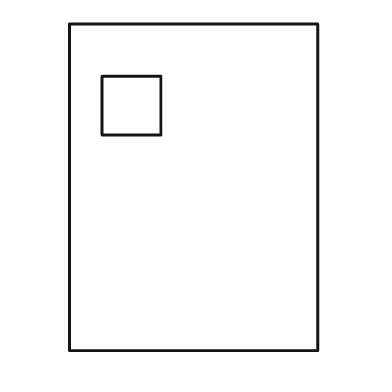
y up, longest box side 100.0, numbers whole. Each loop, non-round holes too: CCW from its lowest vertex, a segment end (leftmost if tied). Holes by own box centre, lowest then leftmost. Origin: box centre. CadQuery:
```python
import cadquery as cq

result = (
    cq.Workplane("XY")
    .moveTo(-38.0, -50.0)
    .lineTo(38.0, -50.0)
    .lineTo(38.0, 50.0)
    .lineTo(-38.0, 50.0)
    .close()
    .moveTo(-28.0, 16.0)
    .lineTo(-10.0, 16.0)
    .lineTo(-10.0, 34.0)
    .lineTo(-28.0, 34.0)
    .close()
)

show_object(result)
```